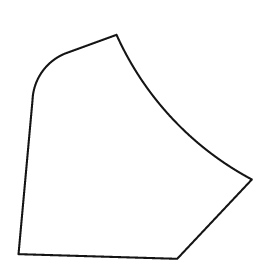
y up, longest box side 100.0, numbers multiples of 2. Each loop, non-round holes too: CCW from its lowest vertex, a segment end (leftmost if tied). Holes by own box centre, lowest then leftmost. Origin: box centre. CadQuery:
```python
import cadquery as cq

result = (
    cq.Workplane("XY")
    .moveTo(18.0, -48.0)
    .lineTo(50.0, -14.0)
    .threePointArc((16.0, 12.0), (-8.0, 48.0))
    .lineTo(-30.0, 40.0)
    .threePointArc((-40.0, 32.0), (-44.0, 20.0))
    .lineTo(-50.0, -46.0)
    .close()
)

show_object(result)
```